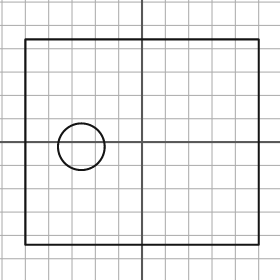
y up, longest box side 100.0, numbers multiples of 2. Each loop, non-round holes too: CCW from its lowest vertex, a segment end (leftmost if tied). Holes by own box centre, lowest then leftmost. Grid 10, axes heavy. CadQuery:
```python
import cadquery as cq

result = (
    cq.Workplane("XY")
    .moveTo(-50.0, -44.0)
    .lineTo(50.0, -44.0)
    .lineTo(50.0, 44.0)
    .lineTo(-50.0, 44.0)
    .close()
    .moveTo(-26.0, -2.0)
    .circle(10.0)
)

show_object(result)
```